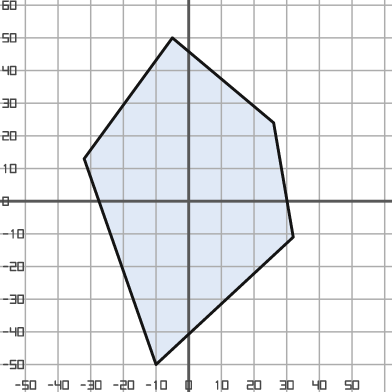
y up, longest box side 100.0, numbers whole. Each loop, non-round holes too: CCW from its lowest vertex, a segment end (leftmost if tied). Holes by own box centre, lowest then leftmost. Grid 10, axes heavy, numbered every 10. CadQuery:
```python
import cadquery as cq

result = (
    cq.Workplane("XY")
    .moveTo(-10.0, -50.0)
    .lineTo(32.0, -11.0)
    .lineTo(26.0, 24.0)
    .lineTo(-5.0, 50.0)
    .lineTo(-32.0, 13.0)
    .close()
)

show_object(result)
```